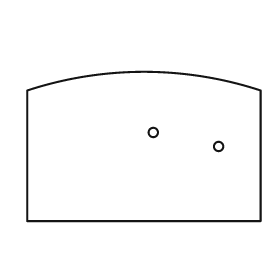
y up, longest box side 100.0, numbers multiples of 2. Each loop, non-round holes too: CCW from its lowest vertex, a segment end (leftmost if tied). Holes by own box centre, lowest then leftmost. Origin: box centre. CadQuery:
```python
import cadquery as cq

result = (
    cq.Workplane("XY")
    .moveTo(-50.0, -32.0)
    .lineTo(50.0, -32.0)
    .lineTo(50.0, 24.0)
    .threePointArc((0.0, 32.0), (-50.0, 24.0))
    .close()
    .moveTo(32.0, 0.0)
    .circle(2.0)
    .moveTo(4.0, 6.0)
    .circle(2.0)
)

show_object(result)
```